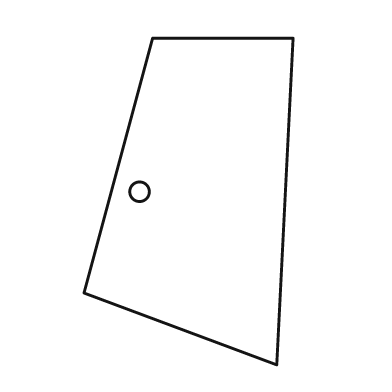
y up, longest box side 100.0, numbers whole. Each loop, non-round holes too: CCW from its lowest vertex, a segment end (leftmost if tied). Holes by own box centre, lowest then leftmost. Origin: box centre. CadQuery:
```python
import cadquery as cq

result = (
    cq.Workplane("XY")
    .moveTo(27.0, -50.0)
    .lineTo(32.0, 50.0)
    .lineTo(-11.0, 50.0)
    .lineTo(-32.0, -28.0)
    .close()
    .moveTo(-15.0, 3.0)
    .circle(3.0)
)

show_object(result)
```